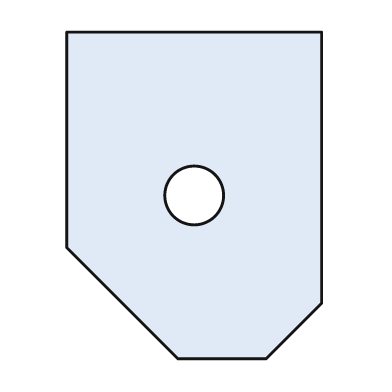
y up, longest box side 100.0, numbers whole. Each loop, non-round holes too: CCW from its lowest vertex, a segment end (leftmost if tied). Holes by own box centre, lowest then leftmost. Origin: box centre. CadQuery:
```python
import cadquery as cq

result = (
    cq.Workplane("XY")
    .moveTo(-5.0, -50.0)
    .lineTo(22.0, -50.0)
    .lineTo(39.0, -33.0)
    .lineTo(39.0, 50.0)
    .lineTo(-39.0, 50.0)
    .lineTo(-39.0, -16.0)
    .close()
    .moveTo(0.0, 0.0)
    .circle(9.0)
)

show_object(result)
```